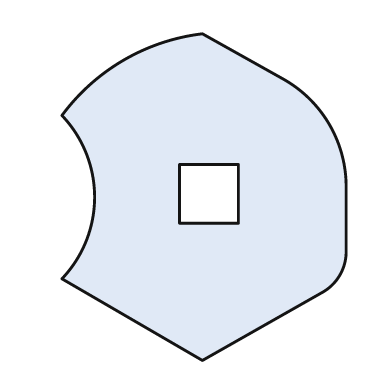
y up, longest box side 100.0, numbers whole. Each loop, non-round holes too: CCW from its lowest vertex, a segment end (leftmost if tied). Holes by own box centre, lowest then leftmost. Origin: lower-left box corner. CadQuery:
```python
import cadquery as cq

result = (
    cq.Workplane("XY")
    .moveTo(43.0, 0.0)
    .lineTo(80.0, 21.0)
    .threePointArc((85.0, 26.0), (87.0, 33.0))
    .lineTo(87.0, 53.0)
    .threePointArc((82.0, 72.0), (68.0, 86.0))
    .lineTo(43.0, 100.0)
    .threePointArc((19.0, 92.0), (0.0, 75.0))
    .threePointArc((10.0, 50.0), (0.0, 25.0))
    .close()
    .moveTo(36.0, 42.0)
    .lineTo(54.0, 42.0)
    .lineTo(54.0, 60.0)
    .lineTo(36.0, 60.0)
    .close()
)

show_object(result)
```